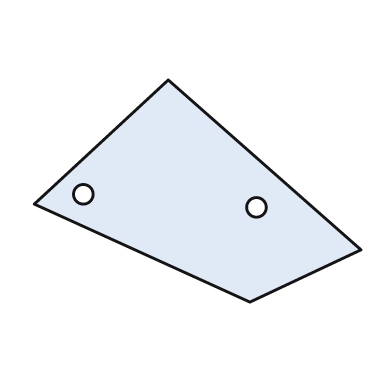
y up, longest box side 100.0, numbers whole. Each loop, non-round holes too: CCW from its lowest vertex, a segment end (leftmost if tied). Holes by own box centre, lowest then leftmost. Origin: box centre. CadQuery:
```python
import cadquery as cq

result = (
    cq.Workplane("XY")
    .moveTo(16.0, -34.0)
    .lineTo(50.0, -18.0)
    .lineTo(-9.0, 34.0)
    .lineTo(-50.0, -4.0)
    .close()
    .moveTo(18.0, -5.0)
    .circle(3.0)
    .moveTo(-35.0, -1.0)
    .circle(3.0)
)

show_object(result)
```